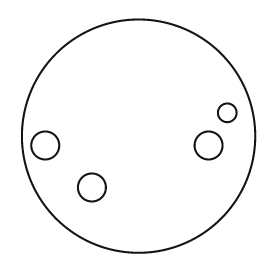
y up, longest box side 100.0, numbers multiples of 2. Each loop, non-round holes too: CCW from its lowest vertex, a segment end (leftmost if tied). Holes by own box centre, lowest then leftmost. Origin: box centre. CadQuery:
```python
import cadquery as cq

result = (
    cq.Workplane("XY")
    .moveTo(0.0, 0.0)
    .circle(50.0)
    .moveTo(-20.0, -22.0)
    .circle(6.0)
    .moveTo(-40.0, -4.0)
    .circle(6.0)
    .moveTo(30.0, -4.0)
    .circle(6.0)
    .moveTo(38.0, 10.0)
    .circle(4.0)
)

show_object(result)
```